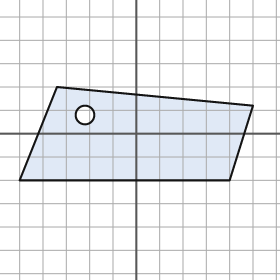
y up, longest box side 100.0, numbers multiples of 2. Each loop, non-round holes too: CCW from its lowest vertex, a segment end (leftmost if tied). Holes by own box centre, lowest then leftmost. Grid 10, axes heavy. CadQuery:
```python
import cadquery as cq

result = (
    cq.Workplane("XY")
    .moveTo(-50.0, -20.0)
    .lineTo(40.0, -20.0)
    .lineTo(50.0, 12.0)
    .lineTo(-34.0, 20.0)
    .close()
    .moveTo(-22.0, 8.0)
    .circle(4.0)
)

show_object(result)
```